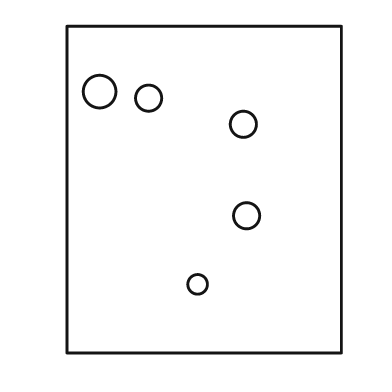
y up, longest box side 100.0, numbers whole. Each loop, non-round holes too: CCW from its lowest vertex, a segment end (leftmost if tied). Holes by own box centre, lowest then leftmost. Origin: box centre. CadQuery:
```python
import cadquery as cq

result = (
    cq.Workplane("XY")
    .moveTo(-42.0, -50.0)
    .lineTo(42.0, -50.0)
    .lineTo(42.0, 50.0)
    .lineTo(-42.0, 50.0)
    .close()
    .moveTo(-2.0, -29.0)
    .circle(3.0)
    .moveTo(13.0, -8.0)
    .circle(4.0)
    .moveTo(12.0, 20.0)
    .circle(4.0)
    .moveTo(-17.0, 28.0)
    .circle(4.0)
    .moveTo(-32.0, 30.0)
    .circle(5.0)
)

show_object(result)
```